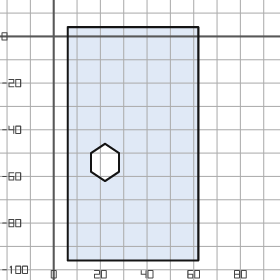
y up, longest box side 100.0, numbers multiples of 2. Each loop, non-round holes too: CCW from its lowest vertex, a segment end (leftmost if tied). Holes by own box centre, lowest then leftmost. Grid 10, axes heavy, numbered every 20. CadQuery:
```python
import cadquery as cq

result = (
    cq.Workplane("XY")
    .moveTo(6.0, -96.0)
    .lineTo(62.0, -96.0)
    .lineTo(62.0, 4.0)
    .lineTo(6.0, 4.0)
    .close()
    .moveTo(22.0, -62.0)
    .lineTo(28.0, -58.0)
    .lineTo(28.0, -50.0)
    .lineTo(22.0, -46.0)
    .lineTo(16.0, -50.0)
    .lineTo(16.0, -58.0)
    .close()
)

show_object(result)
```